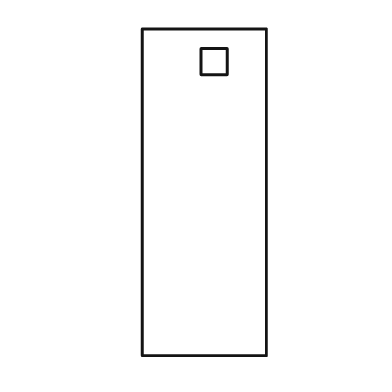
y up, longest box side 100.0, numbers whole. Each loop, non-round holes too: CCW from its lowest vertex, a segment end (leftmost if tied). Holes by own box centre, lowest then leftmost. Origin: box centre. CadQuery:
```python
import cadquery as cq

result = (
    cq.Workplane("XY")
    .moveTo(-19.0, -50.0)
    .lineTo(19.0, -50.0)
    .lineTo(19.0, 50.0)
    .lineTo(-19.0, 50.0)
    .close()
    .moveTo(-1.0, 36.0)
    .lineTo(7.0, 36.0)
    .lineTo(7.0, 44.0)
    .lineTo(-1.0, 44.0)
    .close()
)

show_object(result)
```